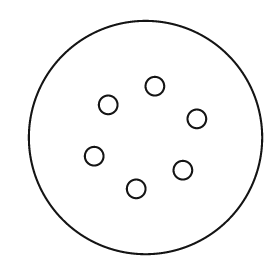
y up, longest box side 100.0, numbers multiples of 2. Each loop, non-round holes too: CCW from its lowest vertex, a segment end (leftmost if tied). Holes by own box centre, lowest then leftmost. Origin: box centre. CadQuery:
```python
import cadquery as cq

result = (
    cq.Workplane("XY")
    .moveTo(0.0, 0.0)
    .circle(50.0)
    .moveTo(-4.0, -22.0)
    .circle(4.0)
    .moveTo(16.0, -14.0)
    .circle(4.0)
    .moveTo(-22.0, -8.0)
    .circle(4.0)
    .moveTo(22.0, 8.0)
    .circle(4.0)
    .moveTo(-16.0, 14.0)
    .circle(4.0)
    .moveTo(4.0, 22.0)
    .circle(4.0)
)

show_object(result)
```